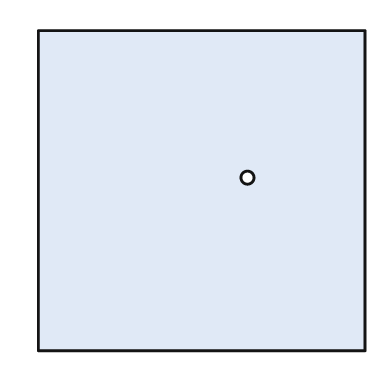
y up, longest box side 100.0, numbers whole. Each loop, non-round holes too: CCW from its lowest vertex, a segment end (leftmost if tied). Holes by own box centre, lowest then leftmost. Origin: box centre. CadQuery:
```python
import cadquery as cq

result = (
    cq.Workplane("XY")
    .moveTo(-50.0, -49.0)
    .lineTo(50.0, -49.0)
    .lineTo(50.0, 49.0)
    .lineTo(-50.0, 49.0)
    .close()
    .moveTo(14.0, 4.0)
    .circle(2.0)
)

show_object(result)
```